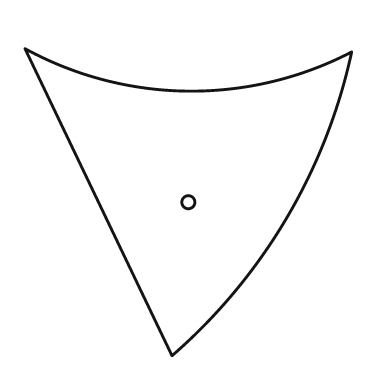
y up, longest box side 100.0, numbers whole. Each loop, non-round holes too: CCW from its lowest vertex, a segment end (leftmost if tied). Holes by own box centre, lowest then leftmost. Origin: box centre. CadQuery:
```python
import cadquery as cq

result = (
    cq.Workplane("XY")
    .moveTo(-5.0, -47.0)
    .threePointArc((30.0, -5.0), (50.0, 46.0))
    .threePointArc((0.0, 34.0), (-50.0, 47.0))
    .close()
    .moveTo(0.0, 0.0)
    .circle(2.0)
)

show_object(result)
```